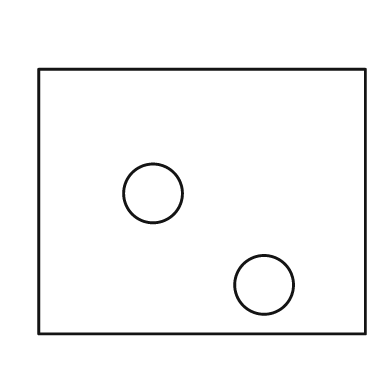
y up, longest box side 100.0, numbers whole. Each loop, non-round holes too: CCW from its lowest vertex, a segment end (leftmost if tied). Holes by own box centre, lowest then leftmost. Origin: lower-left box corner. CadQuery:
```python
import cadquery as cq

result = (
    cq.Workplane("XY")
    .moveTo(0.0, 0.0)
    .lineTo(100.0, 0.0)
    .lineTo(100.0, 81.0)
    .lineTo(0.0, 81.0)
    .close()
    .moveTo(69.0, 15.0)
    .circle(9.0)
    .moveTo(35.0, 43.0)
    .circle(9.0)
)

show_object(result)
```